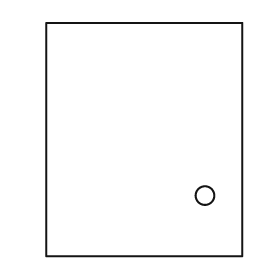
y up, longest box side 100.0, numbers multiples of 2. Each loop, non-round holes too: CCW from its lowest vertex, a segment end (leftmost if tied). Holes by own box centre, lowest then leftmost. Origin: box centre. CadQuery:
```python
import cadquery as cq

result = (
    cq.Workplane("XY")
    .moveTo(-42.0, -50.0)
    .lineTo(42.0, -50.0)
    .lineTo(42.0, 50.0)
    .lineTo(-42.0, 50.0)
    .close()
    .moveTo(26.0, -24.0)
    .circle(4.0)
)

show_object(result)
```